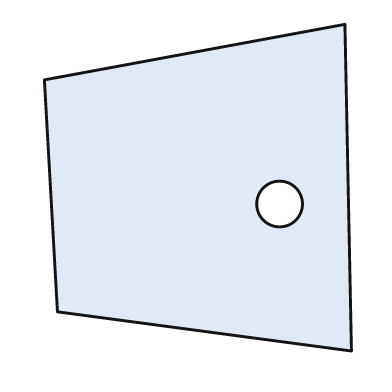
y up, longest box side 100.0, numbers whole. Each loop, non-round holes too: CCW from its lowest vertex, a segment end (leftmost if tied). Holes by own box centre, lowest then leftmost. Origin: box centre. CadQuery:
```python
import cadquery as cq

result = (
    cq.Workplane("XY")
    .moveTo(47.0, -50.0)
    .lineTo(45.0, 50.0)
    .lineTo(-47.0, 33.0)
    .lineTo(-43.0, -38.0)
    .close()
    .moveTo(25.0, -5.0)
    .circle(7.0)
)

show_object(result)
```